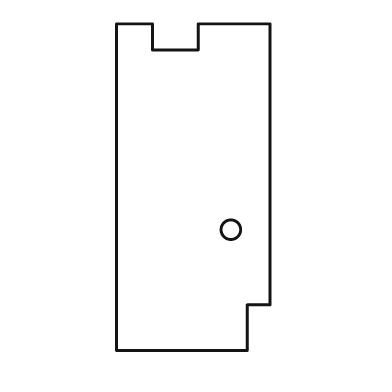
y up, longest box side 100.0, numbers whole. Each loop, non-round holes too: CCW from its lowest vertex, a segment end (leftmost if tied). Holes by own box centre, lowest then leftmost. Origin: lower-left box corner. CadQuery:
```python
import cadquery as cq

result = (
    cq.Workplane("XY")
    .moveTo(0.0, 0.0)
    .lineTo(40.0, 0.0)
    .lineTo(40.0, 14.0)
    .lineTo(47.0, 14.0)
    .lineTo(47.0, 100.0)
    .lineTo(25.0, 100.0)
    .lineTo(25.0, 92.0)
    .lineTo(11.0, 92.0)
    .lineTo(11.0, 100.0)
    .lineTo(0.0, 100.0)
    .close()
    .moveTo(35.0, 37.0)
    .circle(3.0)
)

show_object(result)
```